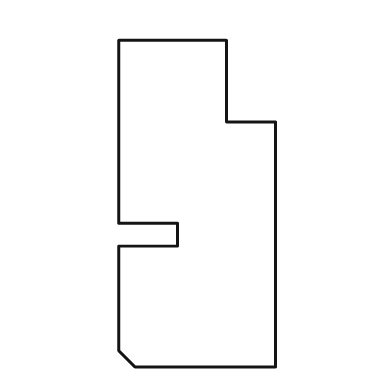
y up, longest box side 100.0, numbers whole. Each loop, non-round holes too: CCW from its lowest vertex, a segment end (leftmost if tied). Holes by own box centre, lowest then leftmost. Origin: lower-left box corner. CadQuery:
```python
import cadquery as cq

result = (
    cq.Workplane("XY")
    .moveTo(5.0, 0.0)
    .lineTo(48.0, 0.0)
    .lineTo(48.0, 75.0)
    .lineTo(33.0, 75.0)
    .lineTo(33.0, 100.0)
    .lineTo(0.0, 100.0)
    .lineTo(0.0, 44.0)
    .lineTo(18.0, 44.0)
    .lineTo(18.0, 37.0)
    .lineTo(0.0, 37.0)
    .lineTo(0.0, 5.0)
    .close()
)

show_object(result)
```